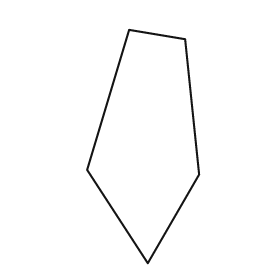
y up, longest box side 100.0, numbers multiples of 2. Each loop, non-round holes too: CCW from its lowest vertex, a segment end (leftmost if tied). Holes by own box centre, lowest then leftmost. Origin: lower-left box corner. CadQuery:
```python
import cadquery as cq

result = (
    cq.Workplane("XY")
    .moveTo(26.0, 0.0)
    .lineTo(48.0, 38.0)
    .lineTo(42.0, 96.0)
    .lineTo(18.0, 100.0)
    .lineTo(0.0, 40.0)
    .close()
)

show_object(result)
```